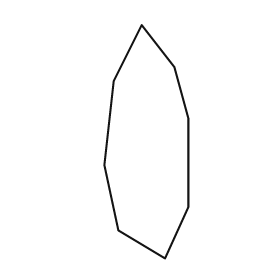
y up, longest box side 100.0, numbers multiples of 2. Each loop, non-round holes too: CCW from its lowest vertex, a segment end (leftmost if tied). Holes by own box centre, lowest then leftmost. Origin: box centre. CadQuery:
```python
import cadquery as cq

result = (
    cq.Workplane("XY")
    .moveTo(8.0, -50.0)
    .lineTo(18.0, -28.0)
    .lineTo(18.0, 10.0)
    .lineTo(12.0, 32.0)
    .lineTo(-2.0, 50.0)
    .lineTo(-14.0, 26.0)
    .lineTo(-18.0, -10.0)
    .lineTo(-12.0, -38.0)
    .close()
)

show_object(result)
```